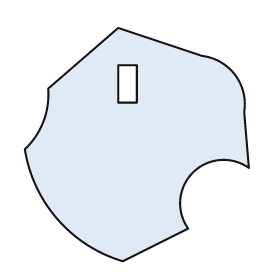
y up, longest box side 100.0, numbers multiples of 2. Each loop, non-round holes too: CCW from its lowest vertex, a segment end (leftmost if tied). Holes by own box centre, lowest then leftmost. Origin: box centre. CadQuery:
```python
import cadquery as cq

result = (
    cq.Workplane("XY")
    .moveTo(-6.0, -50.0)
    .lineTo(22.0, -36.0)
    .threePointArc((24.0, -12.0), (48.0, -10.0))
    .lineTo(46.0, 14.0)
    .threePointArc((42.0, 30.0), (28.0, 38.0))
    .lineTo(-8.0, 50.0)
    .lineTo(-38.0, 24.0)
    .threePointArc((-40.0, 10.0), (-48.0, -2.0))
    .threePointArc((-34.0, -32.0), (-6.0, -50.0))
    .close()
    .moveTo(-8.0, 18.0)
    .lineTo(0.0, 18.0)
    .lineTo(0.0, 34.0)
    .lineTo(-8.0, 34.0)
    .close()
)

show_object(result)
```